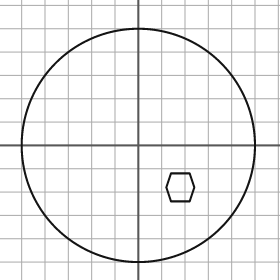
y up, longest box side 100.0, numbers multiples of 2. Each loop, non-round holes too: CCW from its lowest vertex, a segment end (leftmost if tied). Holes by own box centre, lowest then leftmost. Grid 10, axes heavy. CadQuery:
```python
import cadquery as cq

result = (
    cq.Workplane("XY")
    .moveTo(0.0, 0.0)
    .circle(50.0)
    .moveTo(14.0, -24.0)
    .lineTo(22.0, -24.0)
    .lineTo(24.0, -18.0)
    .lineTo(22.0, -12.0)
    .lineTo(14.0, -12.0)
    .lineTo(12.0, -18.0)
    .close()
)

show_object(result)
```